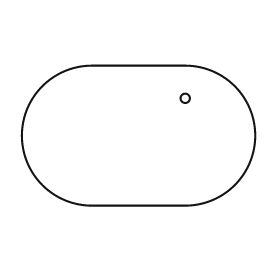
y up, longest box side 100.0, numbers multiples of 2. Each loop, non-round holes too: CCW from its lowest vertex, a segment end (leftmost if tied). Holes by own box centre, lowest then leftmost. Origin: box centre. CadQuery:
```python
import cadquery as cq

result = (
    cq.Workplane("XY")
    .moveTo(-20.0, -30.0)
    .lineTo(20.0, -30.0)
    .threePointArc((50.0, 0.0), (20.0, 30.0))
    .lineTo(-20.0, 30.0)
    .threePointArc((-50.0, 0.0), (-20.0, -30.0))
    .close()
    .moveTo(20.0, 16.0)
    .circle(2.0)
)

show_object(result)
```